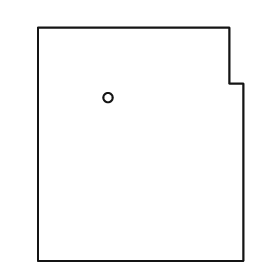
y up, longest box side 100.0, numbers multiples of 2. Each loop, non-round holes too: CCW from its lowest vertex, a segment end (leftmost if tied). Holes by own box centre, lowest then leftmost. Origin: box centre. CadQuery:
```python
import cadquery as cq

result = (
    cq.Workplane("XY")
    .moveTo(-44.0, -50.0)
    .lineTo(44.0, -50.0)
    .lineTo(44.0, 26.0)
    .lineTo(38.0, 26.0)
    .lineTo(38.0, 50.0)
    .lineTo(-44.0, 50.0)
    .close()
    .moveTo(-14.0, 20.0)
    .circle(2.0)
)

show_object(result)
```